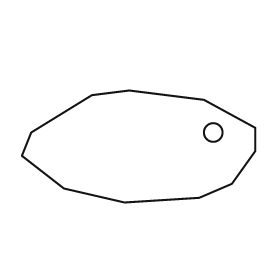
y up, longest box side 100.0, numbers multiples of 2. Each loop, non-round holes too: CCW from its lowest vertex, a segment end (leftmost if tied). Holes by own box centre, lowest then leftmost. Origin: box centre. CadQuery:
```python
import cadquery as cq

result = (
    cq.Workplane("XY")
    .moveTo(-6.0, -24.0)
    .lineTo(26.0, -22.0)
    .lineTo(40.0, -16.0)
    .lineTo(50.0, -2.0)
    .lineTo(50.0, 8.0)
    .lineTo(28.0, 20.0)
    .lineTo(-4.0, 24.0)
    .lineTo(-20.0, 22.0)
    .lineTo(-46.0, 6.0)
    .lineTo(-50.0, -4.0)
    .lineTo(-32.0, -18.0)
    .close()
    .moveTo(32.0, 6.0)
    .circle(4.0)
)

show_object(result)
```